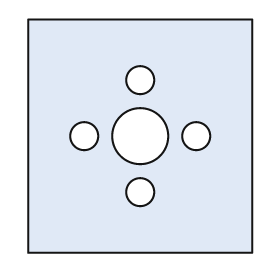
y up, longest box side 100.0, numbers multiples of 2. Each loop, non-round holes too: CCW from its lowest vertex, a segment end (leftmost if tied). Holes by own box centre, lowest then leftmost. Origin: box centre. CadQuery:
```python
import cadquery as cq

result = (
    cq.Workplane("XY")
    .moveTo(-48.0, -50.0)
    .lineTo(48.0, -50.0)
    .lineTo(48.0, 50.0)
    .lineTo(-48.0, 50.0)
    .close()
    .moveTo(0.0, -24.0)
    .circle(6.0)
    .moveTo(-24.0, 0.0)
    .circle(6.0)
    .moveTo(0.0, 0.0)
    .circle(12.0)
    .moveTo(24.0, 0.0)
    .circle(6.0)
    .moveTo(0.0, 24.0)
    .circle(6.0)
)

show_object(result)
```